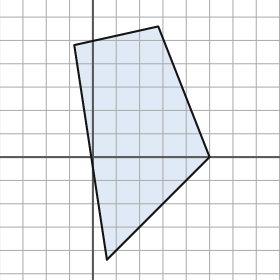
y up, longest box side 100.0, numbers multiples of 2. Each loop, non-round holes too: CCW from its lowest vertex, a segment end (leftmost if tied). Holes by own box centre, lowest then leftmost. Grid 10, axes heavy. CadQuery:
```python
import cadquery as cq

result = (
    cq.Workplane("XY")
    .moveTo(6.0, -44.0)
    .lineTo(50.0, 0.0)
    .lineTo(28.0, 56.0)
    .lineTo(-8.0, 48.0)
    .close()
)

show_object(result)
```